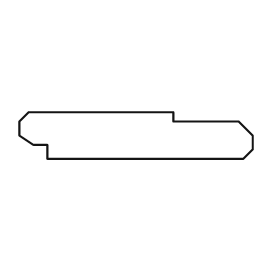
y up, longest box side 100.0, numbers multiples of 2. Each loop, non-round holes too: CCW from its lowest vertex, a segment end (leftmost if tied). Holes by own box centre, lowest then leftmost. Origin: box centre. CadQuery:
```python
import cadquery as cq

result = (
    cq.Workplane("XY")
    .moveTo(-38.0, -10.0)
    .lineTo(46.0, -10.0)
    .lineTo(50.0, -6.0)
    .lineTo(50.0, 0.0)
    .lineTo(44.0, 6.0)
    .lineTo(16.0, 6.0)
    .lineTo(16.0, 10.0)
    .lineTo(-46.0, 10.0)
    .lineTo(-50.0, 6.0)
    .lineTo(-50.0, 0.0)
    .lineTo(-44.0, -4.0)
    .lineTo(-38.0, -4.0)
    .close()
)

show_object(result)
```